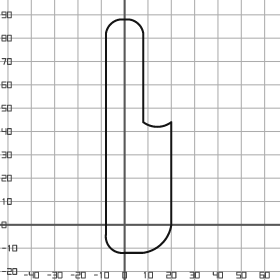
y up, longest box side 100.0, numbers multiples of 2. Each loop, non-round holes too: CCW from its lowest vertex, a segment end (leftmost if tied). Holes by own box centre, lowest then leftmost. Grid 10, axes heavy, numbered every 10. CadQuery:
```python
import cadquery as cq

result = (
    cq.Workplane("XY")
    .moveTo(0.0, -12.0)
    .lineTo(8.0, -12.0)
    .threePointArc((16.0, -8.0), (20.0, 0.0))
    .lineTo(20.0, 44.0)
    .threePointArc((14.0, 42.0), (8.0, 44.0))
    .lineTo(8.0, 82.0)
    .threePointArc((6.0, 86.0), (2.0, 88.0))
    .lineTo(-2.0, 88.0)
    .threePointArc((-6.0, 86.0), (-8.0, 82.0))
    .lineTo(-8.0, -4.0)
    .threePointArc((-6.0, -10.0), (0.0, -12.0))
    .close()
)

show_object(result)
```